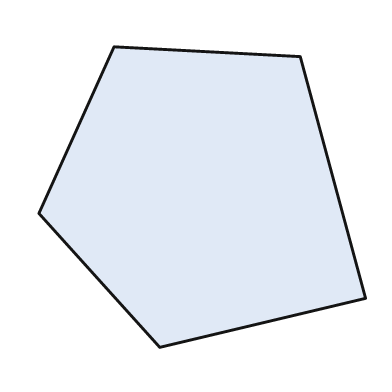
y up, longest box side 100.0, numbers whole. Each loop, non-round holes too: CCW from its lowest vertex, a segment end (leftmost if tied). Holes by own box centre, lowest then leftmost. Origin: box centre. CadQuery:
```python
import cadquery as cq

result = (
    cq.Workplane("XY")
    .moveTo(-13.0, -46.0)
    .lineTo(50.0, -31.0)
    .lineTo(30.0, 43.0)
    .lineTo(-27.0, 46.0)
    .lineTo(-50.0, -5.0)
    .close()
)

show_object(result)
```